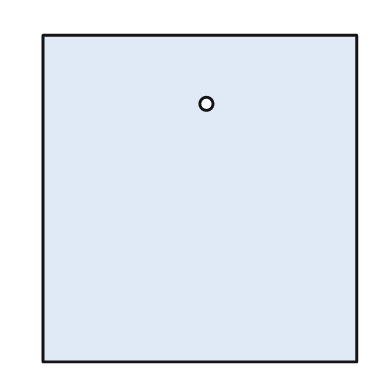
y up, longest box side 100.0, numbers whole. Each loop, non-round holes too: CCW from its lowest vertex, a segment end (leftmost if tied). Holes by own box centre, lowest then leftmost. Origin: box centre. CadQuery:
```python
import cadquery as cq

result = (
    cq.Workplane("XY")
    .moveTo(-48.0, -50.0)
    .lineTo(48.0, -50.0)
    .lineTo(48.0, 50.0)
    .lineTo(-48.0, 50.0)
    .close()
    .moveTo(2.0, 29.0)
    .circle(2.0)
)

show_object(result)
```